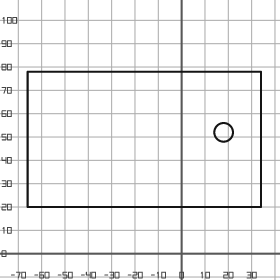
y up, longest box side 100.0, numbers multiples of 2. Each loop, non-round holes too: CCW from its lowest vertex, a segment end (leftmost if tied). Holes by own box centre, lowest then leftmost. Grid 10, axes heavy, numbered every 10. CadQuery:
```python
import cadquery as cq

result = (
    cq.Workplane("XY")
    .moveTo(-66.0, 20.0)
    .lineTo(34.0, 20.0)
    .lineTo(34.0, 78.0)
    .lineTo(-66.0, 78.0)
    .close()
    .moveTo(18.0, 52.0)
    .circle(4.0)
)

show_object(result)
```